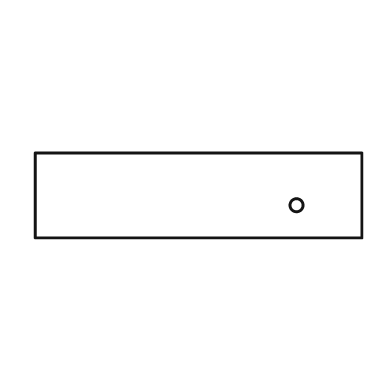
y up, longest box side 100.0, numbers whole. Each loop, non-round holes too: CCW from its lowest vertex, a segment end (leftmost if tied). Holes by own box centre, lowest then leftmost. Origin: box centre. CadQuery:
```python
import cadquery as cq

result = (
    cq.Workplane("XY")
    .moveTo(-50.0, -13.0)
    .lineTo(50.0, -13.0)
    .lineTo(50.0, 13.0)
    .lineTo(-50.0, 13.0)
    .close()
    .moveTo(30.0, -3.0)
    .circle(2.0)
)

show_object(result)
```